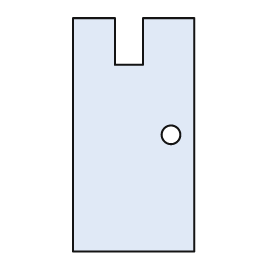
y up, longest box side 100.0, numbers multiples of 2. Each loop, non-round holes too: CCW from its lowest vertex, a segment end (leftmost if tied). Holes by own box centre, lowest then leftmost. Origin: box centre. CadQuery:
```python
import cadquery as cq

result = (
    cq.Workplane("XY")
    .moveTo(-26.0, -50.0)
    .lineTo(26.0, -50.0)
    .lineTo(26.0, 50.0)
    .lineTo(4.0, 50.0)
    .lineTo(4.0, 30.0)
    .lineTo(-8.0, 30.0)
    .lineTo(-8.0, 50.0)
    .lineTo(-26.0, 50.0)
    .close()
    .moveTo(16.0, 0.0)
    .circle(4.0)
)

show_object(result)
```